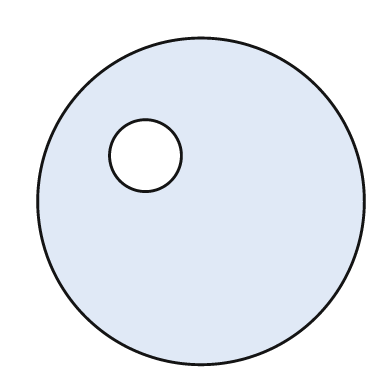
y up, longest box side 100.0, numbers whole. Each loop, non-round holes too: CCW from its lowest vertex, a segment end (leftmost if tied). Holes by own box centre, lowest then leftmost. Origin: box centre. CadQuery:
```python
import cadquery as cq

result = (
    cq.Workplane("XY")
    .moveTo(0.0, 0.0)
    .circle(50.0)
    .moveTo(-17.0, 14.0)
    .circle(11.0)
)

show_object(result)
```